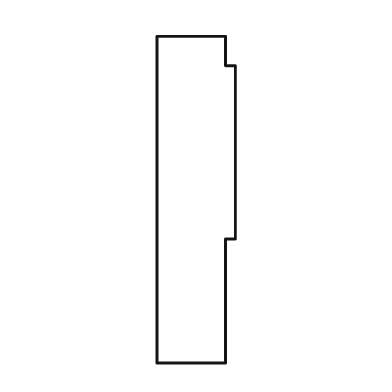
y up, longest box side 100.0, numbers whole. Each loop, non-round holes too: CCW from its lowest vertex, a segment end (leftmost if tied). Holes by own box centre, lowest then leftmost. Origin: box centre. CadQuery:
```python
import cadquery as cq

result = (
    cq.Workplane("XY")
    .moveTo(-12.0, -50.0)
    .lineTo(9.0, -50.0)
    .lineTo(9.0, -12.0)
    .lineTo(12.0, -12.0)
    .lineTo(12.0, 41.0)
    .lineTo(9.0, 41.0)
    .lineTo(9.0, 50.0)
    .lineTo(-12.0, 50.0)
    .close()
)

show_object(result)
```